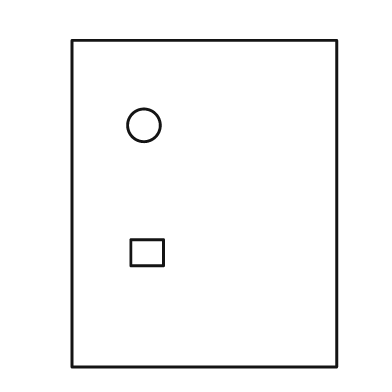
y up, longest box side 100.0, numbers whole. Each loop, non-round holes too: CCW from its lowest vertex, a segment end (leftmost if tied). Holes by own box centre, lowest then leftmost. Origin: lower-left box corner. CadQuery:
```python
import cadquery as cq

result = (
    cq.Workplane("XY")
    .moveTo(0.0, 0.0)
    .lineTo(81.0, 0.0)
    .lineTo(81.0, 100.0)
    .lineTo(0.0, 100.0)
    .close()
    .moveTo(18.0, 31.0)
    .lineTo(28.0, 31.0)
    .lineTo(28.0, 39.0)
    .lineTo(18.0, 39.0)
    .close()
    .moveTo(22.0, 74.0)
    .circle(5.0)
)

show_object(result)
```